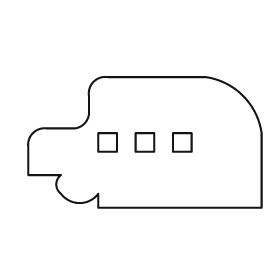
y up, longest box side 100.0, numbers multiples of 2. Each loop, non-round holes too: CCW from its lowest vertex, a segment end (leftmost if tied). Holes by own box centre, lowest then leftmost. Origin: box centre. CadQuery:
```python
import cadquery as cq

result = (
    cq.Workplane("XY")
    .moveTo(-20.0, -28.0)
    .lineTo(50.0, -28.0)
    .lineTo(50.0, 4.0)
    .threePointArc((42.0, 20.0), (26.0, 28.0))
    .lineTo(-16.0, 28.0)
    .threePointArc((-22.0, 26.0), (-24.0, 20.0))
    .lineTo(-24.0, 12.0)
    .threePointArc((-26.0, 8.0), (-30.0, 6.0))
    .lineTo(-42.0, 6.0)
    .threePointArc((-48.0, 4.0), (-50.0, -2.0))
    .lineTo(-50.0, -14.0)
    .lineTo(-36.0, -14.0)
    .threePointArc((-38.0, -18.0), (-36.0, -22.0))
    .threePointArc((-28.0, -26.0), (-20.0, -22.0))
    .close()
    .moveTo(-20.0, -4.0)
    .lineTo(-12.0, -4.0)
    .lineTo(-12.0, 4.0)
    .lineTo(-20.0, 4.0)
    .close()
    .moveTo(-4.0, -4.0)
    .lineTo(4.0, -4.0)
    .lineTo(4.0, 4.0)
    .lineTo(-4.0, 4.0)
    .close()
    .moveTo(12.0, -4.0)
    .lineTo(20.0, -4.0)
    .lineTo(20.0, 4.0)
    .lineTo(12.0, 4.0)
    .close()
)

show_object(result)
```